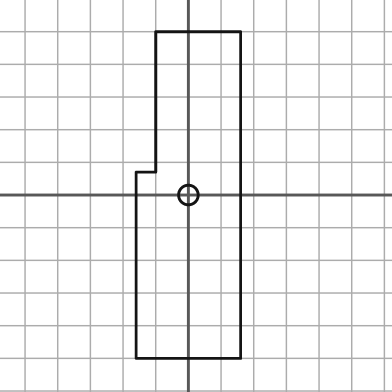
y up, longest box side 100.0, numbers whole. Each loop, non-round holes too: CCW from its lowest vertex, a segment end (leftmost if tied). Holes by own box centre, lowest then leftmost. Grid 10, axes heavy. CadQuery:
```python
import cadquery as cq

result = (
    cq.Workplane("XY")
    .moveTo(-16.0, -50.0)
    .lineTo(16.0, -50.0)
    .lineTo(16.0, 50.0)
    .lineTo(-10.0, 50.0)
    .lineTo(-10.0, 7.0)
    .lineTo(-16.0, 7.0)
    .close()
    .moveTo(0.0, 0.0)
    .circle(3.0)
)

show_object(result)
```